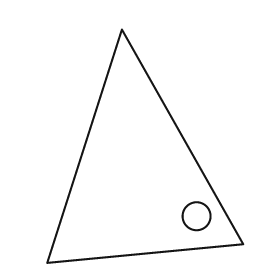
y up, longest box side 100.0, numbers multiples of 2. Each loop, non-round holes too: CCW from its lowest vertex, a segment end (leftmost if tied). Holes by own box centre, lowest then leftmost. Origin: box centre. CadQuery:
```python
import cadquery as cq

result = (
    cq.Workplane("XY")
    .moveTo(-42.0, -50.0)
    .lineTo(42.0, -42.0)
    .lineTo(-10.0, 50.0)
    .close()
    .moveTo(22.0, -30.0)
    .circle(6.0)
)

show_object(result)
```